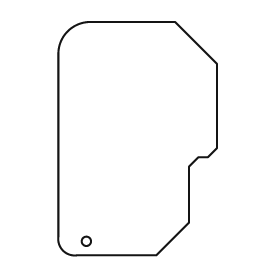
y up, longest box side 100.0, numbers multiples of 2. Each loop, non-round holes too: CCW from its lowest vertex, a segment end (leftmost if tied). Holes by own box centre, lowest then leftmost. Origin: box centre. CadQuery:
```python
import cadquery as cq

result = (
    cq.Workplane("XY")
    .moveTo(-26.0, -50.0)
    .lineTo(8.0, -50.0)
    .lineTo(22.0, -36.0)
    .lineTo(22.0, -12.0)
    .lineTo(26.0, -8.0)
    .lineTo(30.0, -8.0)
    .lineTo(34.0, -4.0)
    .lineTo(34.0, 32.0)
    .lineTo(16.0, 50.0)
    .lineTo(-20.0, 50.0)
    .threePointArc((-30.0, 46.0), (-34.0, 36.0))
    .lineTo(-34.0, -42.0)
    .threePointArc((-32.0, -48.0), (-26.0, -50.0))
    .close()
    .moveTo(-22.0, -44.0)
    .circle(2.0)
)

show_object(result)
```